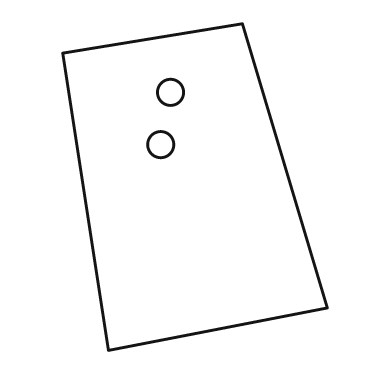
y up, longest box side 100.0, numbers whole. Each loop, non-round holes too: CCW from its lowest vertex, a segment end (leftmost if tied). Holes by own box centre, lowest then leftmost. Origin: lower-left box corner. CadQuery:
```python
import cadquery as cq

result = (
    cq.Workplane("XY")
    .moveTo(14.0, 0.0)
    .lineTo(81.0, 13.0)
    .lineTo(55.0, 100.0)
    .lineTo(0.0, 91.0)
    .close()
    .moveTo(30.0, 63.0)
    .circle(4.0)
    .moveTo(33.0, 79.0)
    .circle(4.0)
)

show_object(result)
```